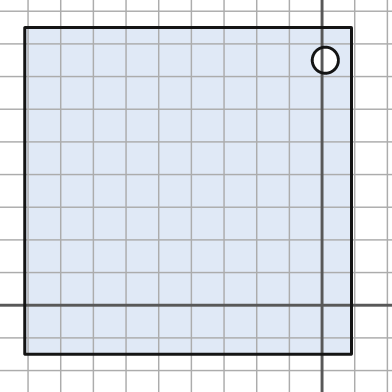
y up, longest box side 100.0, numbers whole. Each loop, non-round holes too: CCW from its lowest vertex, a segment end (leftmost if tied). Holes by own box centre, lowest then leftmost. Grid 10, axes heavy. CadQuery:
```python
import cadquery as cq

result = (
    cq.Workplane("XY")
    .moveTo(-91.0, -15.0)
    .lineTo(9.0, -15.0)
    .lineTo(9.0, 85.0)
    .lineTo(-91.0, 85.0)
    .close()
    .moveTo(1.0, 75.0)
    .circle(4.0)
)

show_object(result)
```